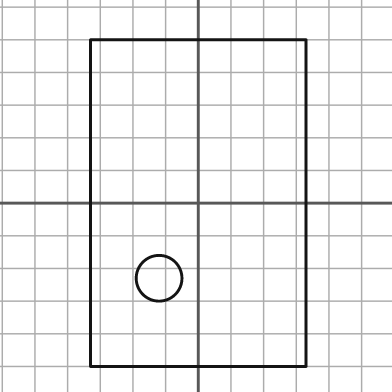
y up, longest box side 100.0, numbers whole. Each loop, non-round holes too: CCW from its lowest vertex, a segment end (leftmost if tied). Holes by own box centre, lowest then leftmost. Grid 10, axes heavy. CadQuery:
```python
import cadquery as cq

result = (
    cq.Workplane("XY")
    .moveTo(-33.0, -50.0)
    .lineTo(33.0, -50.0)
    .lineTo(33.0, 50.0)
    .lineTo(-33.0, 50.0)
    .close()
    .moveTo(-12.0, -23.0)
    .circle(7.0)
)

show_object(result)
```